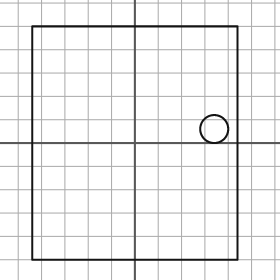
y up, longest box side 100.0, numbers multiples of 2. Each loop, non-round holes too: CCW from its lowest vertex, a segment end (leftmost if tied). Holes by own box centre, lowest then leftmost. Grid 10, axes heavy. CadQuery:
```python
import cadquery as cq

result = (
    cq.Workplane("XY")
    .moveTo(-44.0, -50.0)
    .lineTo(44.0, -50.0)
    .lineTo(44.0, 50.0)
    .lineTo(-44.0, 50.0)
    .close()
    .moveTo(34.0, 6.0)
    .circle(6.0)
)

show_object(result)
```